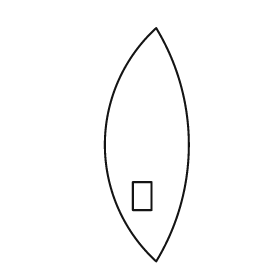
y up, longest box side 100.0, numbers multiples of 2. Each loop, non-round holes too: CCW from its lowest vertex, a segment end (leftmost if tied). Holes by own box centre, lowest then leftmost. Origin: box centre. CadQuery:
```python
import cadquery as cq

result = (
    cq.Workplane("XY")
    .moveTo(4.0, -50.0)
    .threePointArc((18.0, 0.0), (4.0, 50.0))
    .threePointArc((-18.0, 0.0), (4.0, -50.0))
    .close()
    .moveTo(-6.0, -28.0)
    .lineTo(2.0, -28.0)
    .lineTo(2.0, -16.0)
    .lineTo(-6.0, -16.0)
    .close()
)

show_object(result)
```